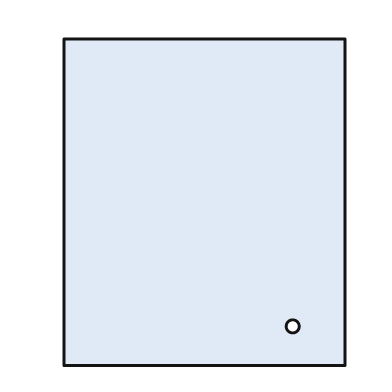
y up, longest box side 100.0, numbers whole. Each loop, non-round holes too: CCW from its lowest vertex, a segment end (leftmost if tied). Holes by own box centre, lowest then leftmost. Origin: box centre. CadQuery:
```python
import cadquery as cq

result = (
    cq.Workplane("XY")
    .moveTo(-43.0, -50.0)
    .lineTo(43.0, -50.0)
    .lineTo(43.0, 50.0)
    .lineTo(-43.0, 50.0)
    .close()
    .moveTo(27.0, -38.0)
    .circle(2.0)
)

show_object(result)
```